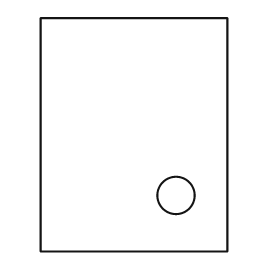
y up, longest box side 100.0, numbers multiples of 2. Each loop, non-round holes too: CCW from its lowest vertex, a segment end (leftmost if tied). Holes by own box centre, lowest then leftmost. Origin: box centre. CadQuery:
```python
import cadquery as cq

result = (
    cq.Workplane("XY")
    .moveTo(-40.0, -50.0)
    .lineTo(40.0, -50.0)
    .lineTo(40.0, 50.0)
    .lineTo(-40.0, 50.0)
    .close()
    .moveTo(18.0, -26.0)
    .circle(8.0)
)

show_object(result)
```